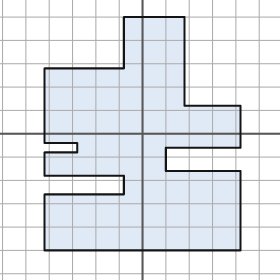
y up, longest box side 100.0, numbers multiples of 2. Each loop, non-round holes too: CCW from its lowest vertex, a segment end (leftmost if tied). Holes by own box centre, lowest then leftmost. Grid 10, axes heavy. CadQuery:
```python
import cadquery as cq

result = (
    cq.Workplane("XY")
    .moveTo(-42.0, -50.0)
    .lineTo(42.0, -50.0)
    .lineTo(42.0, -16.0)
    .lineTo(10.0, -16.0)
    .lineTo(10.0, -6.0)
    .lineTo(42.0, -6.0)
    .lineTo(42.0, 12.0)
    .lineTo(18.0, 12.0)
    .lineTo(18.0, 50.0)
    .lineTo(-8.0, 50.0)
    .lineTo(-8.0, 28.0)
    .lineTo(-42.0, 28.0)
    .lineTo(-42.0, -4.0)
    .lineTo(-28.0, -4.0)
    .lineTo(-28.0, -8.0)
    .lineTo(-42.0, -8.0)
    .lineTo(-42.0, -18.0)
    .lineTo(-8.0, -18.0)
    .lineTo(-8.0, -26.0)
    .lineTo(-42.0, -26.0)
    .close()
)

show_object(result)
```